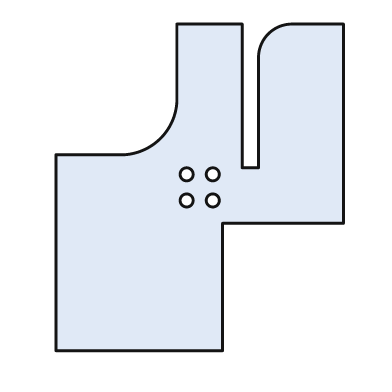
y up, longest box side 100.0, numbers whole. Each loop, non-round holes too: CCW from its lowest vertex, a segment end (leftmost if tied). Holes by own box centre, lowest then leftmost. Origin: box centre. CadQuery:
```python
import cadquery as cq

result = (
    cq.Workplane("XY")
    .moveTo(-44.0, -50.0)
    .lineTo(7.0, -50.0)
    .lineTo(7.0, -11.0)
    .lineTo(44.0, -11.0)
    .lineTo(44.0, 50.0)
    .lineTo(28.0, 50.0)
    .threePointArc((21.0, 47.0), (18.0, 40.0))
    .lineTo(18.0, 6.0)
    .lineTo(13.0, 6.0)
    .lineTo(13.0, 50.0)
    .lineTo(-7.0, 50.0)
    .lineTo(-7.0, 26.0)
    .threePointArc((-12.0, 15.0), (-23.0, 10.0))
    .lineTo(-44.0, 10.0)
    .close()
    .moveTo(-4.0, -4.0)
    .circle(2.0)
    .moveTo(4.0, -4.0)
    .circle(2.0)
    .moveTo(-4.0, 4.0)
    .circle(2.0)
    .moveTo(4.0, 4.0)
    .circle(2.0)
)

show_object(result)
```